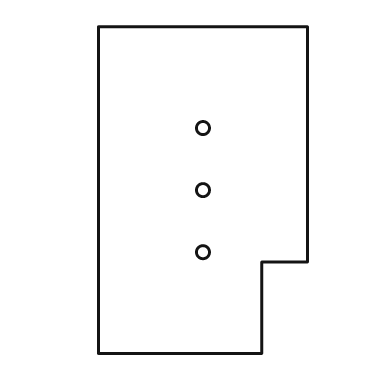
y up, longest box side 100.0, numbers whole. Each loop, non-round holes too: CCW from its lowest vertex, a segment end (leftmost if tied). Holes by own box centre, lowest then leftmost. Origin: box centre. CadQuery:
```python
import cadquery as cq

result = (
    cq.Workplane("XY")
    .moveTo(-32.0, -50.0)
    .lineTo(18.0, -50.0)
    .lineTo(18.0, -22.0)
    .lineTo(32.0, -22.0)
    .lineTo(32.0, 50.0)
    .lineTo(-32.0, 50.0)
    .close()
    .moveTo(0.0, -19.0)
    .circle(2.0)
    .moveTo(0.0, 0.0)
    .circle(2.0)
    .moveTo(0.0, 19.0)
    .circle(2.0)
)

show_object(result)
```